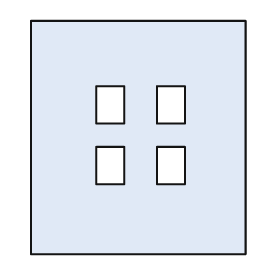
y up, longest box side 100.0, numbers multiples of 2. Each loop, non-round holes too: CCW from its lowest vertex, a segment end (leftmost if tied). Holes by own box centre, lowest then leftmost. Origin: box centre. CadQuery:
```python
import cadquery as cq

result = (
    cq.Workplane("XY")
    .moveTo(-46.0, -50.0)
    .lineTo(46.0, -50.0)
    .lineTo(46.0, 50.0)
    .lineTo(-46.0, 50.0)
    .close()
    .moveTo(-18.0, -20.0)
    .lineTo(-6.0, -20.0)
    .lineTo(-6.0, -4.0)
    .lineTo(-18.0, -4.0)
    .close()
    .moveTo(8.0, -20.0)
    .lineTo(20.0, -20.0)
    .lineTo(20.0, -4.0)
    .lineTo(8.0, -4.0)
    .close()
    .moveTo(-18.0, 6.0)
    .lineTo(-6.0, 6.0)
    .lineTo(-6.0, 22.0)
    .lineTo(-18.0, 22.0)
    .close()
    .moveTo(8.0, 6.0)
    .lineTo(20.0, 6.0)
    .lineTo(20.0, 22.0)
    .lineTo(8.0, 22.0)
    .close()
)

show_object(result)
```